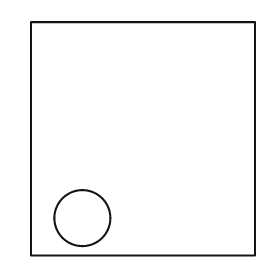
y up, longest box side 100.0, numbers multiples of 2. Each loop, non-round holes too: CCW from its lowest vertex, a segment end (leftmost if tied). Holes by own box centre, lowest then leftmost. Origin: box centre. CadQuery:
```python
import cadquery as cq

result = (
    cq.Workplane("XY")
    .moveTo(-48.0, -50.0)
    .lineTo(48.0, -50.0)
    .lineTo(48.0, 50.0)
    .lineTo(-48.0, 50.0)
    .close()
    .moveTo(-26.0, -34.0)
    .circle(12.0)
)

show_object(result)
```